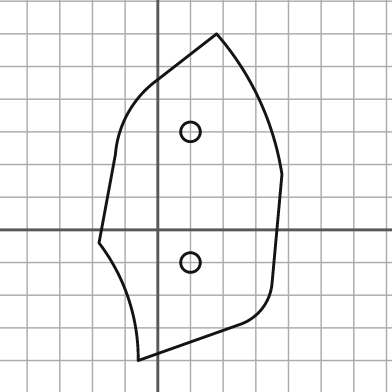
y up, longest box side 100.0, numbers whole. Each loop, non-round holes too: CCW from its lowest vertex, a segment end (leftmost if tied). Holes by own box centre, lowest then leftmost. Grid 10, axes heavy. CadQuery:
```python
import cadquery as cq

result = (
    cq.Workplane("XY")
    .moveTo(-6.0, -40.0)
    .lineTo(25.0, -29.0)
    .threePointArc((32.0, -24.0), (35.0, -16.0))
    .lineTo(38.0, 17.0)
    .threePointArc((31.0, 40.0), (18.0, 60.0))
    .lineTo(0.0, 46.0)
    .threePointArc((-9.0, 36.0), (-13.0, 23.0))
    .lineTo(-18.0, -4.0)
    .threePointArc((-9.0, -21.0), (-6.0, -40.0))
    .close()
    .moveTo(10.0, -10.0)
    .circle(3.0)
    .moveTo(10.0, 30.0)
    .circle(3.0)
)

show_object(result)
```